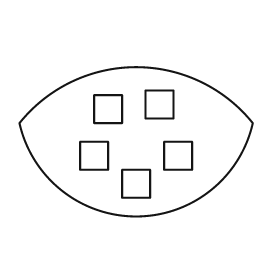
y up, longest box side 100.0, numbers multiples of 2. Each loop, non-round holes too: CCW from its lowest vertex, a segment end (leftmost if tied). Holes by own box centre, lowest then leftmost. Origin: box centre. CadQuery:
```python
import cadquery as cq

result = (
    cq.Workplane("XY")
    .moveTo(-50.0, 8.0)
    .threePointArc((0.0, -32.0), (50.0, 8.0))
    .threePointArc((0.0, 32.0), (-50.0, 8.0))
    .close()
    .moveTo(-6.0, -24.0)
    .lineTo(6.0, -24.0)
    .lineTo(6.0, -12.0)
    .lineTo(-6.0, -12.0)
    .close()
    .moveTo(-24.0, -12.0)
    .lineTo(-12.0, -12.0)
    .lineTo(-12.0, 0.0)
    .lineTo(-24.0, 0.0)
    .close()
    .moveTo(12.0, -12.0)
    .lineTo(24.0, -12.0)
    .lineTo(24.0, 0.0)
    .lineTo(12.0, 0.0)
    .close()
    .moveTo(-18.0, 8.0)
    .lineTo(-6.0, 8.0)
    .lineTo(-6.0, 20.0)
    .lineTo(-18.0, 20.0)
    .close()
    .moveTo(4.0, 10.0)
    .lineTo(16.0, 10.0)
    .lineTo(16.0, 22.0)
    .lineTo(4.0, 22.0)
    .close()
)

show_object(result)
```